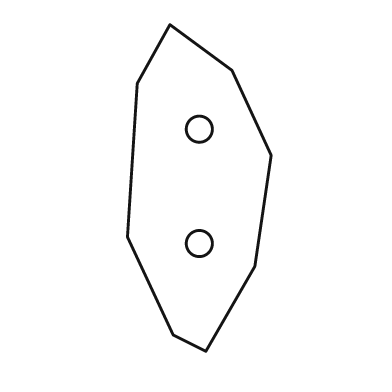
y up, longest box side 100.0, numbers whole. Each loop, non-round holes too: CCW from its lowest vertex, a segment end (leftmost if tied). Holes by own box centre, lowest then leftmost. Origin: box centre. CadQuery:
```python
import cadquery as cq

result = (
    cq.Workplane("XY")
    .moveTo(2.0, -50.0)
    .lineTo(17.0, -24.0)
    .lineTo(22.0, 10.0)
    .lineTo(10.0, 36.0)
    .lineTo(-9.0, 50.0)
    .lineTo(-19.0, 32.0)
    .lineTo(-22.0, -15.0)
    .lineTo(-8.0, -45.0)
    .close()
    .moveTo(0.0, -17.0)
    .circle(4.0)
    .moveTo(0.0, 18.0)
    .circle(4.0)
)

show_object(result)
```